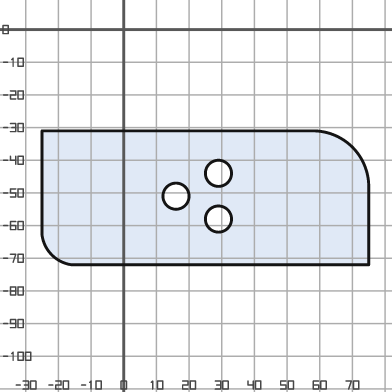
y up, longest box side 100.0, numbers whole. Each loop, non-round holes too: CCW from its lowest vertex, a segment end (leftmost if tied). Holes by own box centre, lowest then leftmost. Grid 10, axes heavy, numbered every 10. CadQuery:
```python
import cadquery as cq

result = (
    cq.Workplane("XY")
    .moveTo(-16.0, -72.0)
    .lineTo(75.0, -72.0)
    .lineTo(75.0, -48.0)
    .threePointArc((70.0, -36.0), (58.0, -31.0))
    .lineTo(-25.0, -31.0)
    .lineTo(-25.0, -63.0)
    .threePointArc((-22.0, -69.0), (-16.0, -72.0))
    .close()
    .moveTo(29.0, -58.0)
    .circle(4.0)
    .moveTo(16.0, -51.0)
    .circle(4.0)
    .moveTo(29.0, -44.0)
    .circle(4.0)
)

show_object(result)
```